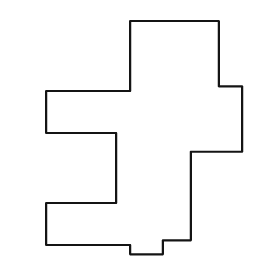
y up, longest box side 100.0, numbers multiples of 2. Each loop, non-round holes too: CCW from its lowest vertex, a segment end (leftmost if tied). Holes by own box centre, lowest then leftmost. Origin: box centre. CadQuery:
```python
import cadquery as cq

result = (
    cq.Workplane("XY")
    .moveTo(-6.0, -50.0)
    .lineTo(8.0, -50.0)
    .lineTo(8.0, -44.0)
    .lineTo(20.0, -44.0)
    .lineTo(20.0, -6.0)
    .lineTo(42.0, -6.0)
    .lineTo(42.0, 22.0)
    .lineTo(32.0, 22.0)
    .lineTo(32.0, 50.0)
    .lineTo(-6.0, 50.0)
    .lineTo(-6.0, 20.0)
    .lineTo(-42.0, 20.0)
    .lineTo(-42.0, 2.0)
    .lineTo(-12.0, 2.0)
    .lineTo(-12.0, -28.0)
    .lineTo(-42.0, -28.0)
    .lineTo(-42.0, -46.0)
    .lineTo(-6.0, -46.0)
    .close()
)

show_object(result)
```